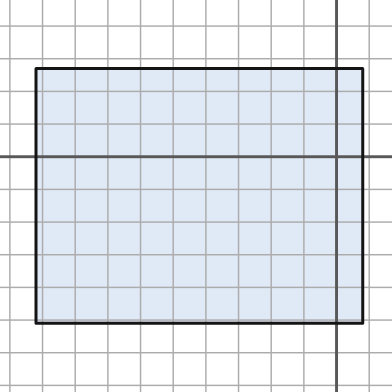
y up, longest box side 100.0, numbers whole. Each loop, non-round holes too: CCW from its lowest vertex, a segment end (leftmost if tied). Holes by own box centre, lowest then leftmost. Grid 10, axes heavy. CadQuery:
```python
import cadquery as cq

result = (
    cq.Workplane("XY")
    .moveTo(-92.0, -51.0)
    .lineTo(8.0, -51.0)
    .lineTo(8.0, 27.0)
    .lineTo(-92.0, 27.0)
    .close()
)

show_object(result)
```